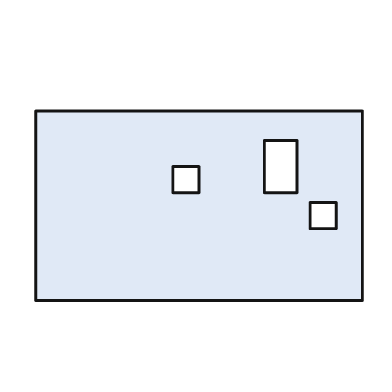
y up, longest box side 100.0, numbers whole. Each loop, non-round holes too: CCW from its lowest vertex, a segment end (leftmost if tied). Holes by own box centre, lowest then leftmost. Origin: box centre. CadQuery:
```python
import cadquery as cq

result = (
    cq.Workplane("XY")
    .moveTo(-50.0, -29.0)
    .lineTo(50.0, -29.0)
    .lineTo(50.0, 29.0)
    .lineTo(-50.0, 29.0)
    .close()
    .moveTo(34.0, -7.0)
    .lineTo(42.0, -7.0)
    .lineTo(42.0, 1.0)
    .lineTo(34.0, 1.0)
    .close()
    .moveTo(-8.0, 4.0)
    .lineTo(0.0, 4.0)
    .lineTo(0.0, 12.0)
    .lineTo(-8.0, 12.0)
    .close()
    .moveTo(20.0, 4.0)
    .lineTo(30.0, 4.0)
    .lineTo(30.0, 20.0)
    .lineTo(20.0, 20.0)
    .close()
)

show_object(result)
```